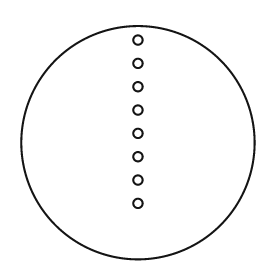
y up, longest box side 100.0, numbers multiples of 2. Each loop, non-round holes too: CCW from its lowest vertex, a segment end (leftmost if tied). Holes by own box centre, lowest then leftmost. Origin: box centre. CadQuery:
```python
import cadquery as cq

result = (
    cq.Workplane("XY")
    .moveTo(0.0, 0.0)
    .circle(50.0)
    .moveTo(0.0, -26.0)
    .circle(2.0)
    .moveTo(0.0, -16.0)
    .circle(2.0)
    .moveTo(0.0, -6.0)
    .circle(2.0)
    .moveTo(0.0, 4.0)
    .circle(2.0)
    .moveTo(0.0, 14.0)
    .circle(2.0)
    .moveTo(0.0, 24.0)
    .circle(2.0)
    .moveTo(0.0, 34.0)
    .circle(2.0)
    .moveTo(0.0, 44.0)
    .circle(2.0)
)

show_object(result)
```